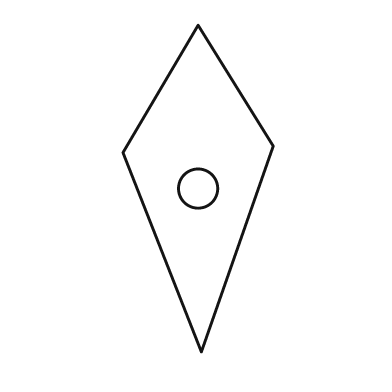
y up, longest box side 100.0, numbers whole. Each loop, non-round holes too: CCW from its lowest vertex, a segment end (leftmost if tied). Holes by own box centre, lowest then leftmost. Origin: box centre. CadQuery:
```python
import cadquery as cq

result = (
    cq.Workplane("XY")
    .moveTo(1.0, -50.0)
    .lineTo(23.0, 13.0)
    .lineTo(0.0, 50.0)
    .lineTo(-23.0, 11.0)
    .close()
    .moveTo(0.0, 0.0)
    .circle(6.0)
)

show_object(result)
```